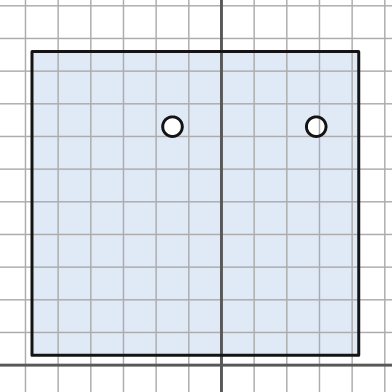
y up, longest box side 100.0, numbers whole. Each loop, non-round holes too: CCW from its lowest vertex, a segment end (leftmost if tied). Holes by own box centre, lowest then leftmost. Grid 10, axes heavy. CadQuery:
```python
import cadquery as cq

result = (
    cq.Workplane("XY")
    .moveTo(-58.0, 3.0)
    .lineTo(42.0, 3.0)
    .lineTo(42.0, 96.0)
    .lineTo(-58.0, 96.0)
    .close()
    .moveTo(-15.0, 73.0)
    .circle(3.0)
    .moveTo(29.0, 73.0)
    .circle(3.0)
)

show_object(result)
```